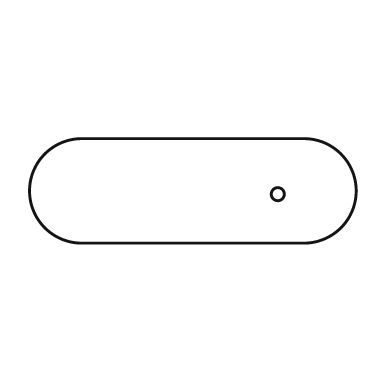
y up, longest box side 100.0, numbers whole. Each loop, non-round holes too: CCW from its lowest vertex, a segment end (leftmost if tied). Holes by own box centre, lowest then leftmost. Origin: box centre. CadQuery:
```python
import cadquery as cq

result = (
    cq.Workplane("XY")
    .moveTo(-34.0, -16.0)
    .lineTo(34.0, -16.0)
    .threePointArc((50.0, 0.0), (34.0, 16.0))
    .lineTo(-34.0, 16.0)
    .threePointArc((-50.0, 0.0), (-34.0, -16.0))
    .close()
    .moveTo(26.0, -1.0)
    .circle(2.0)
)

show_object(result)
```